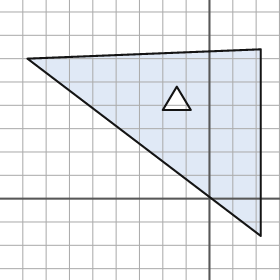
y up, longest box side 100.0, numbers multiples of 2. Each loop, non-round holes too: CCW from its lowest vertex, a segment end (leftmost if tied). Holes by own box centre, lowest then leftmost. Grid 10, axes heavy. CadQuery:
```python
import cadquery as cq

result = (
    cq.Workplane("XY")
    .moveTo(22.0, -16.0)
    .lineTo(22.0, 64.0)
    .lineTo(-78.0, 60.0)
    .close()
    .moveTo(-20.0, 38.0)
    .lineTo(-8.0, 38.0)
    .lineTo(-14.0, 48.0)
    .close()
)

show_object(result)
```